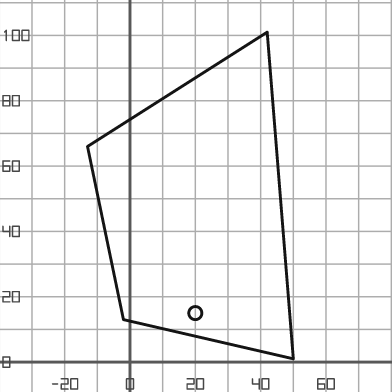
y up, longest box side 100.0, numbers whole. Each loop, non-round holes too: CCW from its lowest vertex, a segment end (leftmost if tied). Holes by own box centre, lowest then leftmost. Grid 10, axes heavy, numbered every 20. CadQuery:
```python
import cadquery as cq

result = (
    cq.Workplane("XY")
    .moveTo(50.0, 1.0)
    .lineTo(42.0, 101.0)
    .lineTo(-13.0, 66.0)
    .lineTo(-2.0, 13.0)
    .close()
    .moveTo(20.0, 15.0)
    .circle(2.0)
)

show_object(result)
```